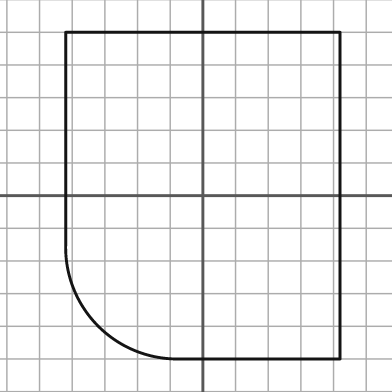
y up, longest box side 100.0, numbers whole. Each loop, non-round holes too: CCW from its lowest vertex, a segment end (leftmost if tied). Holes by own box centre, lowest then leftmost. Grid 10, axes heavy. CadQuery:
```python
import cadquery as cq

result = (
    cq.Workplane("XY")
    .moveTo(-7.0, -50.0)
    .lineTo(42.0, -50.0)
    .lineTo(42.0, 50.0)
    .lineTo(-42.0, 50.0)
    .lineTo(-42.0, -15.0)
    .threePointArc((-32.0, -40.0), (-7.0, -50.0))
    .close()
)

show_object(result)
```